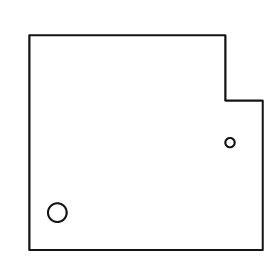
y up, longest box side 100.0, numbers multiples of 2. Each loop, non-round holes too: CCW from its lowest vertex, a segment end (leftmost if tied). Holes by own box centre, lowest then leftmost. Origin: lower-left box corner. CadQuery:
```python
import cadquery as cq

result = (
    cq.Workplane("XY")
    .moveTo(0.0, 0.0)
    .lineTo(100.0, 0.0)
    .lineTo(100.0, 64.0)
    .lineTo(84.0, 64.0)
    .lineTo(84.0, 92.0)
    .lineTo(0.0, 92.0)
    .close()
    .moveTo(12.0, 16.0)
    .circle(4.0)
    .moveTo(86.0, 46.0)
    .circle(2.0)
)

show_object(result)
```